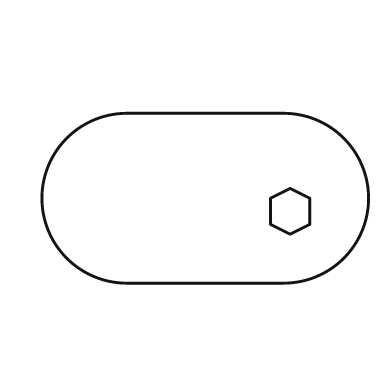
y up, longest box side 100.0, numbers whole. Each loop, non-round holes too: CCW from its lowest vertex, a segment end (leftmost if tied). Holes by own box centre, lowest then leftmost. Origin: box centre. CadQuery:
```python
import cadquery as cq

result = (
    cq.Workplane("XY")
    .moveTo(-24.0, -26.0)
    .lineTo(24.0, -26.0)
    .threePointArc((50.0, 0.0), (24.0, 26.0))
    .lineTo(-24.0, 26.0)
    .threePointArc((-50.0, 0.0), (-24.0, -26.0))
    .close()
    .moveTo(26.0, -11.0)
    .lineTo(32.0, -8.0)
    .lineTo(32.0, 0.0)
    .lineTo(26.0, 3.0)
    .lineTo(20.0, 0.0)
    .lineTo(20.0, -8.0)
    .close()
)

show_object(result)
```